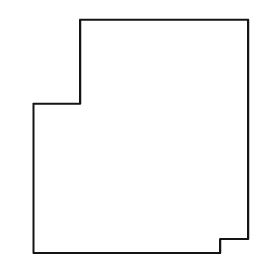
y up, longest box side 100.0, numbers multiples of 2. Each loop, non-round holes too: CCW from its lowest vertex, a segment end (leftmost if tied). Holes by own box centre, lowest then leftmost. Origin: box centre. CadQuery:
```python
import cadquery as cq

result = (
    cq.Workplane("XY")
    .moveTo(-46.0, -50.0)
    .lineTo(34.0, -50.0)
    .lineTo(34.0, -44.0)
    .lineTo(46.0, -44.0)
    .lineTo(46.0, 50.0)
    .lineTo(-26.0, 50.0)
    .lineTo(-26.0, 14.0)
    .lineTo(-46.0, 14.0)
    .close()
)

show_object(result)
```